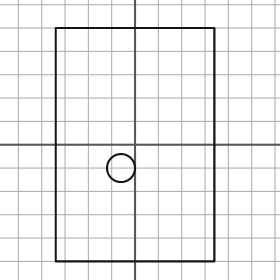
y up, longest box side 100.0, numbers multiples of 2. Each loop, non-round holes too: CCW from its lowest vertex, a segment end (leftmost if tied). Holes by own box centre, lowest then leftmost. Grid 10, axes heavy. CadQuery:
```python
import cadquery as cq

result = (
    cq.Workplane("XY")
    .moveTo(-34.0, -50.0)
    .lineTo(34.0, -50.0)
    .lineTo(34.0, 50.0)
    .lineTo(-34.0, 50.0)
    .close()
    .moveTo(-6.0, -10.0)
    .circle(6.0)
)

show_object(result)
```